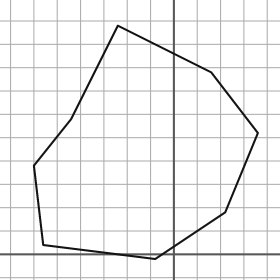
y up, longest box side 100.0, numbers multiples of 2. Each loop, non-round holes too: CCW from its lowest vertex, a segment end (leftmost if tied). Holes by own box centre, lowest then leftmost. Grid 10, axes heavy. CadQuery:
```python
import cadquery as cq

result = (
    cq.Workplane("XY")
    .moveTo(-8.0, -2.0)
    .lineTo(22.0, 18.0)
    .lineTo(36.0, 52.0)
    .lineTo(16.0, 78.0)
    .lineTo(-24.0, 98.0)
    .lineTo(-44.0, 58.0)
    .lineTo(-60.0, 38.0)
    .lineTo(-56.0, 4.0)
    .close()
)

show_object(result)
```